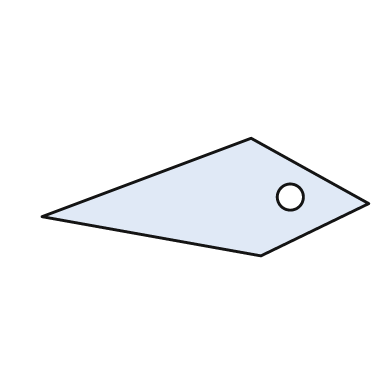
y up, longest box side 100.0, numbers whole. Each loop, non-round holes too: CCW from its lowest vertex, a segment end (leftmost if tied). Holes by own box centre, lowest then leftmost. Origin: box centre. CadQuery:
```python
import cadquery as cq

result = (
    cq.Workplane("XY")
    .moveTo(17.0, -18.0)
    .lineTo(50.0, -2.0)
    .lineTo(14.0, 18.0)
    .lineTo(-50.0, -6.0)
    .close()
    .moveTo(26.0, 0.0)
    .circle(4.0)
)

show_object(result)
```